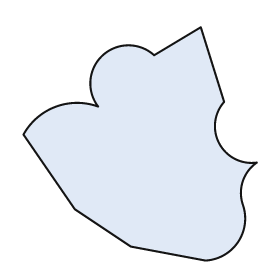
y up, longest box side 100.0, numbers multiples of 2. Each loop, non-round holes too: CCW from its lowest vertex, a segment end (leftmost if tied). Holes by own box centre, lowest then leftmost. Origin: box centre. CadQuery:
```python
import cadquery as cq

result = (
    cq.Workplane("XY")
    .moveTo(28.0, -50.0)
    .threePointArc((42.0, -42.0), (44.0, -26.0))
    .threePointArc((44.0, -16.0), (50.0, -8.0))
    .threePointArc((34.0, 0.0), (36.0, 18.0))
    .lineTo(26.0, 50.0)
    .lineTo(6.0, 38.0)
    .threePointArc((-16.0, 38.0), (-18.0, 16.0))
    .threePointArc((-36.0, 16.0), (-50.0, 4.0))
    .lineTo(-28.0, -28.0)
    .lineTo(-4.0, -44.0)
    .close()
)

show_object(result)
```